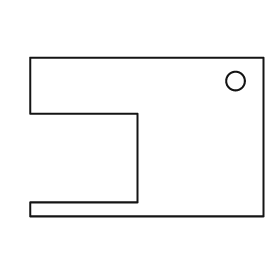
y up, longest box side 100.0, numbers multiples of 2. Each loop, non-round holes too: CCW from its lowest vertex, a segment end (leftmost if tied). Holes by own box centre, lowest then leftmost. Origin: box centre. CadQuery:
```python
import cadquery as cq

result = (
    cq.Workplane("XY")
    .moveTo(-50.0, -34.0)
    .lineTo(50.0, -34.0)
    .lineTo(50.0, 34.0)
    .lineTo(-50.0, 34.0)
    .lineTo(-50.0, 10.0)
    .lineTo(-4.0, 10.0)
    .lineTo(-4.0, -28.0)
    .lineTo(-50.0, -28.0)
    .close()
    .moveTo(38.0, 24.0)
    .circle(4.0)
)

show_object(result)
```